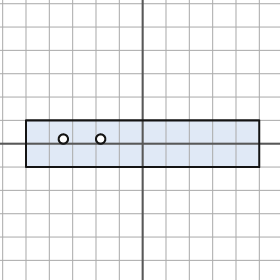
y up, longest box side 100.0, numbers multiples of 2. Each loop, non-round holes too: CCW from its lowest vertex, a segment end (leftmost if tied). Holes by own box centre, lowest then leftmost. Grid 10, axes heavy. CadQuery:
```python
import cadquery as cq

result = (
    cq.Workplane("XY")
    .moveTo(-50.0, -10.0)
    .lineTo(50.0, -10.0)
    .lineTo(50.0, 10.0)
    .lineTo(-50.0, 10.0)
    .close()
    .moveTo(-34.0, 2.0)
    .circle(2.0)
    .moveTo(-18.0, 2.0)
    .circle(2.0)
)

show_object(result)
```